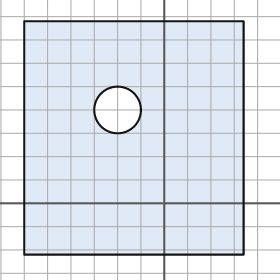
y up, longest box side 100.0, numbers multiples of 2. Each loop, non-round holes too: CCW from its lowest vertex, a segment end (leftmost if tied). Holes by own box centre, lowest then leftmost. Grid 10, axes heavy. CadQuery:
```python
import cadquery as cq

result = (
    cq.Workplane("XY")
    .moveTo(-60.0, -22.0)
    .lineTo(34.0, -22.0)
    .lineTo(34.0, 78.0)
    .lineTo(-60.0, 78.0)
    .close()
    .moveTo(-20.0, 40.0)
    .circle(10.0)
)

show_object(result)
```